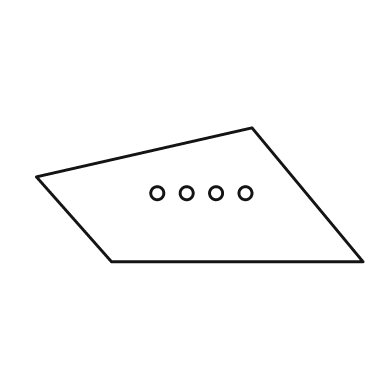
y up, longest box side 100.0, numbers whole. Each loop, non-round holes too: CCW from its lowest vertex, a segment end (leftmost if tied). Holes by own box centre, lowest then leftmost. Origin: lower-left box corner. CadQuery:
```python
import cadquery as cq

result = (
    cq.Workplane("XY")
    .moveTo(23.0, 0.0)
    .lineTo(100.0, 0.0)
    .lineTo(66.0, 41.0)
    .lineTo(0.0, 26.0)
    .close()
    .moveTo(37.0, 21.0)
    .circle(2.0)
    .moveTo(46.0, 21.0)
    .circle(2.0)
    .moveTo(55.0, 21.0)
    .circle(2.0)
    .moveTo(64.0, 21.0)
    .circle(2.0)
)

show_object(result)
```